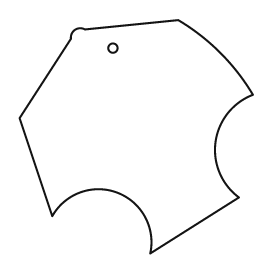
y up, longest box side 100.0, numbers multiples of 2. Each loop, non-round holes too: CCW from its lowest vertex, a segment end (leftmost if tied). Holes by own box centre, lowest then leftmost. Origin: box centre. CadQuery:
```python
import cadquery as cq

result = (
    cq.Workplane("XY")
    .moveTo(6.0, -50.0)
    .lineTo(44.0, -26.0)
    .threePointArc((34.0, -2.0), (50.0, 18.0))
    .threePointArc((36.0, 36.0), (18.0, 50.0))
    .lineTo(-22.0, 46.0)
    .threePointArc((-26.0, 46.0), (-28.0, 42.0))
    .lineTo(-50.0, 8.0)
    .lineTo(-36.0, -34.0)
    .threePointArc((-8.0, -24.0), (6.0, -50.0))
    .close()
    .moveTo(-10.0, 38.0)
    .circle(2.0)
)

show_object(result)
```